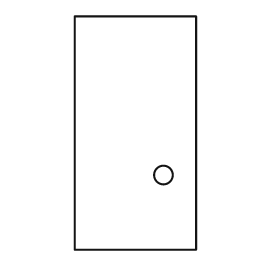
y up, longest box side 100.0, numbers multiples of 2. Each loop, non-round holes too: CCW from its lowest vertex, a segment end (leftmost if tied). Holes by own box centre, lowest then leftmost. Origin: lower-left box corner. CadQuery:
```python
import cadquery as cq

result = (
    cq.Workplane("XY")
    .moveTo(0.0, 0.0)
    .lineTo(52.0, 0.0)
    .lineTo(52.0, 100.0)
    .lineTo(0.0, 100.0)
    .close()
    .moveTo(38.0, 32.0)
    .circle(4.0)
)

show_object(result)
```